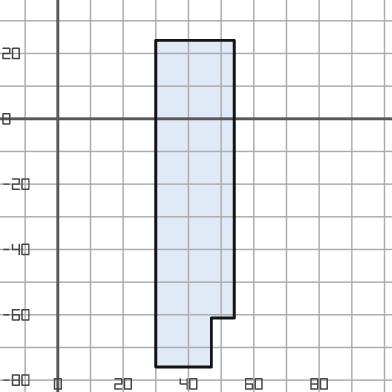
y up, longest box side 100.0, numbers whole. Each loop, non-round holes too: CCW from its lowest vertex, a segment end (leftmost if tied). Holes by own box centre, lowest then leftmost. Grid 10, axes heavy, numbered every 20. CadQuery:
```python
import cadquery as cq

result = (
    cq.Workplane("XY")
    .moveTo(30.0, -76.0)
    .lineTo(47.0, -76.0)
    .lineTo(47.0, -61.0)
    .lineTo(54.0, -61.0)
    .lineTo(54.0, 24.0)
    .lineTo(30.0, 24.0)
    .close()
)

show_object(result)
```